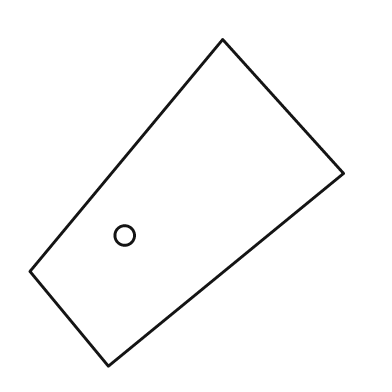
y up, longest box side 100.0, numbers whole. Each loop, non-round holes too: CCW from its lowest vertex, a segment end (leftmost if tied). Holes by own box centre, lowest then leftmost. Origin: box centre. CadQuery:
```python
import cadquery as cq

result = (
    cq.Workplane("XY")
    .moveTo(-24.0, -50.0)
    .lineTo(48.0, 9.0)
    .lineTo(11.0, 50.0)
    .lineTo(-48.0, -21.0)
    .close()
    .moveTo(-19.0, -10.0)
    .circle(3.0)
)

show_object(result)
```